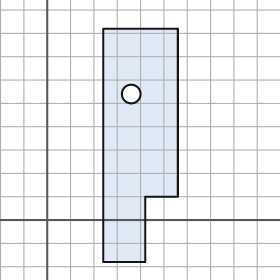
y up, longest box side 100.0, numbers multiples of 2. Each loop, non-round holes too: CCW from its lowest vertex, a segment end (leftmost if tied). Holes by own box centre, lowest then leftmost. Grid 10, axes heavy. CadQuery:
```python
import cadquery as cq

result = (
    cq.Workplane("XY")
    .moveTo(24.0, -18.0)
    .lineTo(42.0, -18.0)
    .lineTo(42.0, 10.0)
    .lineTo(56.0, 10.0)
    .lineTo(56.0, 82.0)
    .lineTo(24.0, 82.0)
    .close()
    .moveTo(36.0, 54.0)
    .circle(4.0)
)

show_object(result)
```